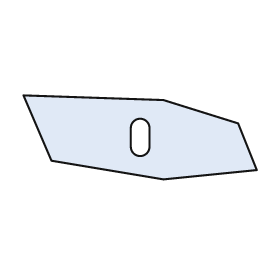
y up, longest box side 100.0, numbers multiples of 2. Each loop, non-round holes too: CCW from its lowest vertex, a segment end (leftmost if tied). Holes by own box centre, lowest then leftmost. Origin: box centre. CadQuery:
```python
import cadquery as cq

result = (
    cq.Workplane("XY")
    .moveTo(10.0, -18.0)
    .lineTo(50.0, -14.0)
    .lineTo(42.0, 6.0)
    .lineTo(10.0, 16.0)
    .lineTo(-50.0, 18.0)
    .lineTo(-38.0, -10.0)
    .close()
    .moveTo(-4.0, -4.0)
    .threePointArc((0.0, -8.0), (4.0, -4.0))
    .lineTo(4.0, 4.0)
    .threePointArc((0.0, 8.0), (-4.0, 4.0))
    .close()
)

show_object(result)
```